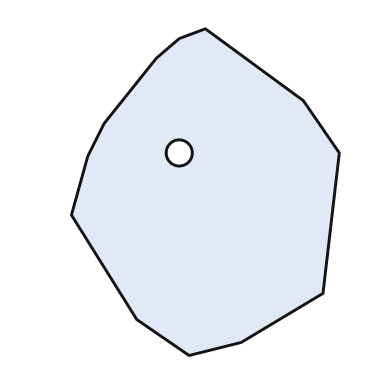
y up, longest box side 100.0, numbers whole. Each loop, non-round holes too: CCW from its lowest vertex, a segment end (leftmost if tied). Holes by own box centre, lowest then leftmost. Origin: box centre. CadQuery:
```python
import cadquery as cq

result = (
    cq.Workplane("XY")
    .moveTo(-5.0, -50.0)
    .lineTo(11.0, -46.0)
    .lineTo(36.0, -31.0)
    .lineTo(41.0, 12.0)
    .lineTo(30.0, 28.0)
    .lineTo(0.0, 50.0)
    .lineTo(-8.0, 47.0)
    .lineTo(-15.0, 41.0)
    .lineTo(-31.0, 21.0)
    .lineTo(-36.0, 11.0)
    .lineTo(-41.0, -7.0)
    .lineTo(-21.0, -39.0)
    .close()
    .moveTo(-8.0, 12.0)
    .circle(4.0)
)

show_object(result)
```